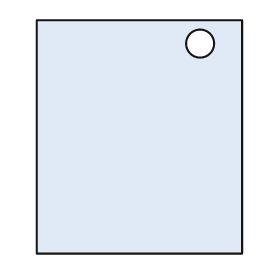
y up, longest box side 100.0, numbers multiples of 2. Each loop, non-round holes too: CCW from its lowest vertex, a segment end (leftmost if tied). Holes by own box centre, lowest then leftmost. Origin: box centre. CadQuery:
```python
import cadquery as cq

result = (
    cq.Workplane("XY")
    .moveTo(-44.0, -50.0)
    .lineTo(44.0, -50.0)
    .lineTo(44.0, 50.0)
    .lineTo(-44.0, 50.0)
    .close()
    .moveTo(26.0, 40.0)
    .circle(6.0)
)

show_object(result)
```